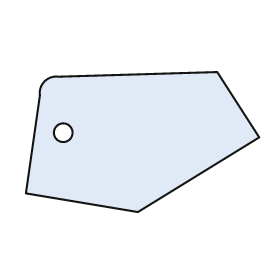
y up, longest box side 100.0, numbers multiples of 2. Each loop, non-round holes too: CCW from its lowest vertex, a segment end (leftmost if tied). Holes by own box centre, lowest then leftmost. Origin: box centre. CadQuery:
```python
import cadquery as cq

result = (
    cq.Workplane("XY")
    .moveTo(-2.0, -30.0)
    .lineTo(50.0, 2.0)
    .lineTo(32.0, 30.0)
    .lineTo(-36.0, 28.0)
    .threePointArc((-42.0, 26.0), (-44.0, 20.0))
    .lineTo(-50.0, -22.0)
    .close()
    .moveTo(-34.0, 4.0)
    .circle(4.0)
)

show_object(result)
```